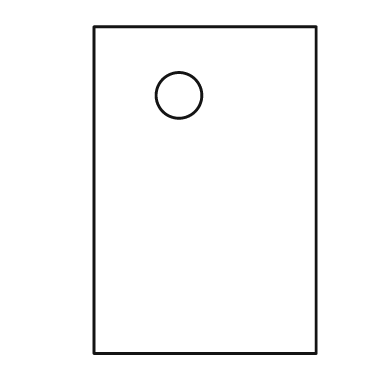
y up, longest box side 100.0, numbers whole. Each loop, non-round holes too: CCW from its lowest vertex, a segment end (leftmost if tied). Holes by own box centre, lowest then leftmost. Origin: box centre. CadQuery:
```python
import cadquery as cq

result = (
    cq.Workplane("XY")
    .moveTo(-34.0, -50.0)
    .lineTo(34.0, -50.0)
    .lineTo(34.0, 50.0)
    .lineTo(-34.0, 50.0)
    .close()
    .moveTo(-8.0, 29.0)
    .circle(7.0)
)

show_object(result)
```